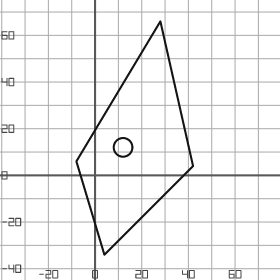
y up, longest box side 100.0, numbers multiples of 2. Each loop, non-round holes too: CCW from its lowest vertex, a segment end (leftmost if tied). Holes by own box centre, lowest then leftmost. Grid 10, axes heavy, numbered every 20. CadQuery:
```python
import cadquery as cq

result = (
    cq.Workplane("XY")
    .moveTo(4.0, -34.0)
    .lineTo(42.0, 4.0)
    .lineTo(28.0, 66.0)
    .lineTo(-8.0, 6.0)
    .close()
    .moveTo(12.0, 12.0)
    .circle(4.0)
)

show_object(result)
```